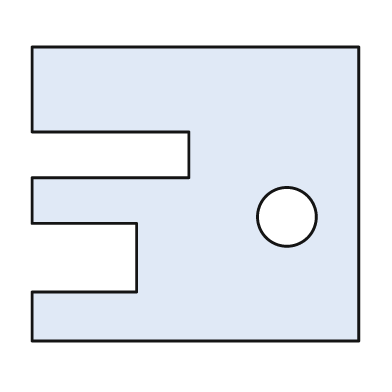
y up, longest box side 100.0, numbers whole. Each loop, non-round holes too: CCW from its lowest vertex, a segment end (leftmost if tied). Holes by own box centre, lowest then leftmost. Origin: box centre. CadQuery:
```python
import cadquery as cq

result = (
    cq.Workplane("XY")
    .moveTo(-50.0, -45.0)
    .lineTo(50.0, -45.0)
    .lineTo(50.0, 45.0)
    .lineTo(-50.0, 45.0)
    .lineTo(-50.0, 19.0)
    .lineTo(-2.0, 19.0)
    .lineTo(-2.0, 5.0)
    .lineTo(-50.0, 5.0)
    .lineTo(-50.0, -9.0)
    .lineTo(-18.0, -9.0)
    .lineTo(-18.0, -30.0)
    .lineTo(-50.0, -30.0)
    .close()
    .moveTo(28.0, -7.0)
    .circle(9.0)
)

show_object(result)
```